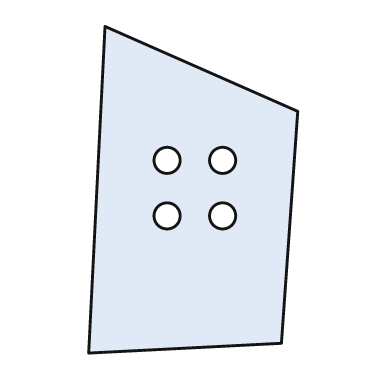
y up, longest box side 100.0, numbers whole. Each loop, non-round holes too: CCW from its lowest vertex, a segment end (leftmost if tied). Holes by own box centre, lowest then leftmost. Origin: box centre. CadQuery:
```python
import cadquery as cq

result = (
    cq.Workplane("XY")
    .moveTo(-32.0, -50.0)
    .lineTo(27.0, -47.0)
    .lineTo(32.0, 24.0)
    .lineTo(-27.0, 50.0)
    .close()
    .moveTo(-8.0, -8.0)
    .circle(4.0)
    .moveTo(9.0, -8.0)
    .circle(4.0)
    .moveTo(-8.0, 9.0)
    .circle(4.0)
    .moveTo(9.0, 9.0)
    .circle(4.0)
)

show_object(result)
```